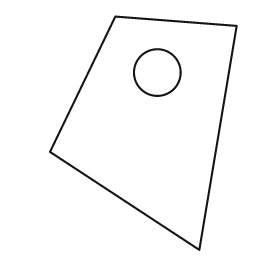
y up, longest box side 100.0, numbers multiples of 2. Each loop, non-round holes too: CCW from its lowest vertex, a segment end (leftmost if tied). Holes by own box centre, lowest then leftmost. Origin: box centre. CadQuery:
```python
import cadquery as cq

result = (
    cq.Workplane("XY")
    .moveTo(24.0, -50.0)
    .lineTo(40.0, 46.0)
    .lineTo(-12.0, 50.0)
    .lineTo(-40.0, -8.0)
    .close()
    .moveTo(6.0, 26.0)
    .circle(10.0)
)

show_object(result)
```